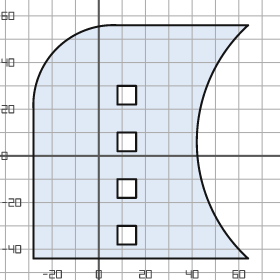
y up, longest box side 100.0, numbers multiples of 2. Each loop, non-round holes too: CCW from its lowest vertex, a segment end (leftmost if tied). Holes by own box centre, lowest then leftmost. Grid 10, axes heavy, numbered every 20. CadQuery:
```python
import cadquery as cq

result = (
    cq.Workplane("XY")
    .moveTo(-28.0, -44.0)
    .lineTo(64.0, -44.0)
    .threePointArc((42.0, 6.0), (64.0, 56.0))
    .lineTo(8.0, 56.0)
    .threePointArc((-18.0, 46.0), (-28.0, 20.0))
    .close()
    .moveTo(8.0, -38.0)
    .lineTo(16.0, -38.0)
    .lineTo(16.0, -30.0)
    .lineTo(8.0, -30.0)
    .close()
    .moveTo(8.0, -18.0)
    .lineTo(16.0, -18.0)
    .lineTo(16.0, -10.0)
    .lineTo(8.0, -10.0)
    .close()
    .moveTo(8.0, 2.0)
    .lineTo(16.0, 2.0)
    .lineTo(16.0, 10.0)
    .lineTo(8.0, 10.0)
    .close()
    .moveTo(8.0, 22.0)
    .lineTo(16.0, 22.0)
    .lineTo(16.0, 30.0)
    .lineTo(8.0, 30.0)
    .close()
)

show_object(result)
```